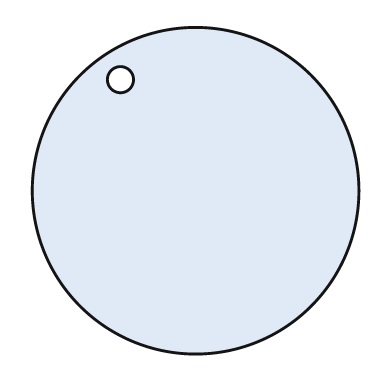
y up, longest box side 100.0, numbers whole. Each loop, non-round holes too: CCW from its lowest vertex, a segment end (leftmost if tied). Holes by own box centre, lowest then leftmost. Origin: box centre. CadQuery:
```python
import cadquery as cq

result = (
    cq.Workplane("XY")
    .moveTo(0.0, 0.0)
    .circle(50.0)
    .moveTo(-23.0, 34.0)
    .circle(4.0)
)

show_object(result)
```